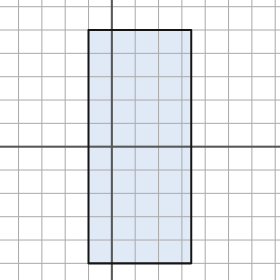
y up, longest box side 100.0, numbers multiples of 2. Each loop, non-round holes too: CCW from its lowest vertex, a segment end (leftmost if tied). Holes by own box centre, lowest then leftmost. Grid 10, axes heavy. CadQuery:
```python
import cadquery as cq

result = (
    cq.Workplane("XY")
    .moveTo(-10.0, -50.0)
    .lineTo(34.0, -50.0)
    .lineTo(34.0, 50.0)
    .lineTo(-10.0, 50.0)
    .close()
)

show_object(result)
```